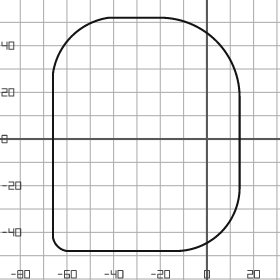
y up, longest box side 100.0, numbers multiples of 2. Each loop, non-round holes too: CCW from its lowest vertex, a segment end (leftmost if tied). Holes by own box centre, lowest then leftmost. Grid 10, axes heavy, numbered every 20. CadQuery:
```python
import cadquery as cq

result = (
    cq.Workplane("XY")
    .moveTo(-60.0, -48.0)
    .lineTo(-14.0, -48.0)
    .threePointArc((6.0, -40.0), (14.0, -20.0))
    .lineTo(14.0, 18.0)
    .threePointArc((4.0, 42.0), (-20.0, 52.0))
    .lineTo(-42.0, 52.0)
    .threePointArc((-58.0, 44.0), (-66.0, 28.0))
    .lineTo(-66.0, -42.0)
    .threePointArc((-64.0, -46.0), (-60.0, -48.0))
    .close()
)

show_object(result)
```